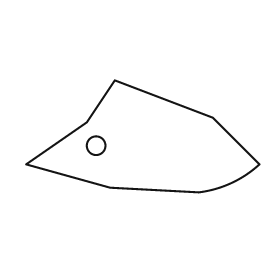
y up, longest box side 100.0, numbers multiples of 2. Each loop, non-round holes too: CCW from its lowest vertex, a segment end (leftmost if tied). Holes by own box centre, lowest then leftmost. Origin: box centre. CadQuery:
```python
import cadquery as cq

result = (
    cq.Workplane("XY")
    .moveTo(24.0, -24.0)
    .threePointArc((38.0, -20.0), (50.0, -12.0))
    .lineTo(30.0, 8.0)
    .lineTo(-12.0, 24.0)
    .lineTo(-24.0, 6.0)
    .lineTo(-50.0, -12.0)
    .lineTo(-14.0, -22.0)
    .close()
    .moveTo(-20.0, -4.0)
    .circle(4.0)
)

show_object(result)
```